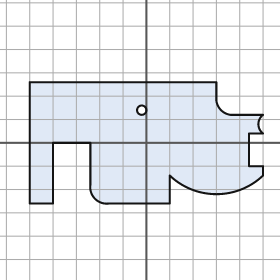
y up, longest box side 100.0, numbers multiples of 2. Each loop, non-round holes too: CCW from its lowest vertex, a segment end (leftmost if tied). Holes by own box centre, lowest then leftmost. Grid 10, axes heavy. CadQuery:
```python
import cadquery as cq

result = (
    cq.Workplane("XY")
    .moveTo(-50.0, -26.0)
    .lineTo(-40.0, -26.0)
    .lineTo(-40.0, 0.0)
    .lineTo(-24.0, 0.0)
    .lineTo(-24.0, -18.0)
    .threePointArc((-22.0, -24.0), (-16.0, -26.0))
    .lineTo(10.0, -26.0)
    .lineTo(10.0, -14.0)
    .threePointArc((30.0, -22.0), (50.0, -14.0))
    .lineTo(50.0, -10.0)
    .lineTo(44.0, -10.0)
    .lineTo(44.0, 4.0)
    .lineTo(50.0, 4.0)
    .threePointArc((48.0, 8.0), (50.0, 12.0))
    .lineTo(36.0, 12.0)
    .threePointArc((32.0, 14.0), (30.0, 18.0))
    .lineTo(30.0, 26.0)
    .lineTo(-50.0, 26.0)
    .close()
    .moveTo(-2.0, 14.0)
    .circle(2.0)
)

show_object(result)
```